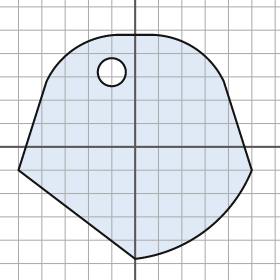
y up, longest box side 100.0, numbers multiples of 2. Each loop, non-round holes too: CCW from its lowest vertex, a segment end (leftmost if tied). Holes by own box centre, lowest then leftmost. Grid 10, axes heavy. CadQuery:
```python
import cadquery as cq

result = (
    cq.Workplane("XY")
    .moveTo(0.0, -48.0)
    .threePointArc((30.0, -36.0), (50.0, -10.0))
    .lineTo(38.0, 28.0)
    .threePointArc((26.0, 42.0), (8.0, 48.0))
    .lineTo(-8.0, 48.0)
    .threePointArc((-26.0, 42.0), (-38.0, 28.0))
    .lineTo(-50.0, -10.0)
    .close()
    .moveTo(-10.0, 32.0)
    .circle(6.0)
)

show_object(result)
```